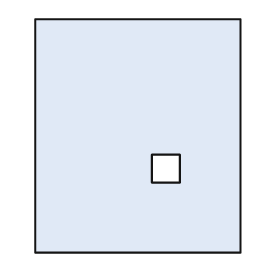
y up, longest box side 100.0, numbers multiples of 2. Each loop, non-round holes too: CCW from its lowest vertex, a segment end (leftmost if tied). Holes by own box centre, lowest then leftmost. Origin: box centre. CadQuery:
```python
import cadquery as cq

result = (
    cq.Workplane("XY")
    .moveTo(-44.0, -50.0)
    .lineTo(44.0, -50.0)
    .lineTo(44.0, 50.0)
    .lineTo(-44.0, 50.0)
    .close()
    .moveTo(6.0, -20.0)
    .lineTo(18.0, -20.0)
    .lineTo(18.0, -8.0)
    .lineTo(6.0, -8.0)
    .close()
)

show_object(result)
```